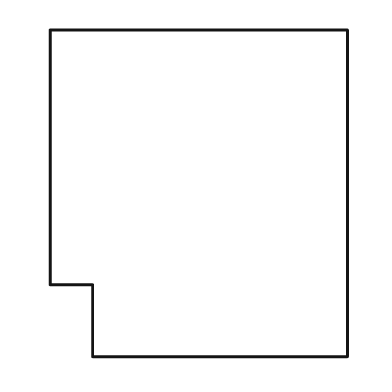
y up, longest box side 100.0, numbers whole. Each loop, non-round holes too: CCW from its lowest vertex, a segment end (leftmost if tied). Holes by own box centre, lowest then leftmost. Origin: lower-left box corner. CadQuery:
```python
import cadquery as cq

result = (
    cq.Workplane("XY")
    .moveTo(13.0, 0.0)
    .lineTo(91.0, 0.0)
    .lineTo(91.0, 100.0)
    .lineTo(0.0, 100.0)
    .lineTo(0.0, 22.0)
    .lineTo(13.0, 22.0)
    .close()
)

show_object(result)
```